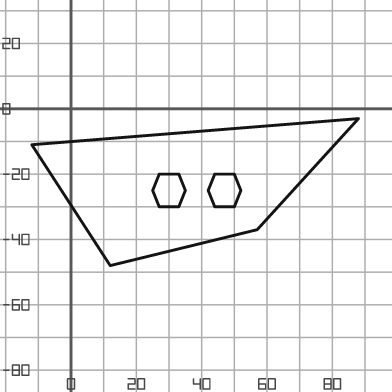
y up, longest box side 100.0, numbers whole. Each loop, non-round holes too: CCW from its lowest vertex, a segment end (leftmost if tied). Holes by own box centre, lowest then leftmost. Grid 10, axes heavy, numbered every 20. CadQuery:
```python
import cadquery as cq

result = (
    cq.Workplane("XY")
    .moveTo(12.0, -48.0)
    .lineTo(57.0, -37.0)
    .lineTo(88.0, -3.0)
    .lineTo(-12.0, -11.0)
    .close()
    .moveTo(27.0, -30.0)
    .lineTo(33.0, -30.0)
    .lineTo(35.0, -25.0)
    .lineTo(33.0, -20.0)
    .lineTo(27.0, -20.0)
    .lineTo(25.0, -25.0)
    .close()
    .moveTo(44.0, -30.0)
    .lineTo(50.0, -30.0)
    .lineTo(52.0, -25.0)
    .lineTo(50.0, -20.0)
    .lineTo(44.0, -20.0)
    .lineTo(42.0, -25.0)
    .close()
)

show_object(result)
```